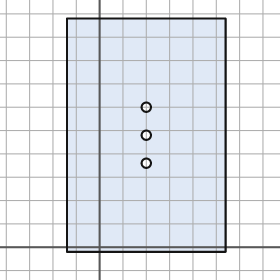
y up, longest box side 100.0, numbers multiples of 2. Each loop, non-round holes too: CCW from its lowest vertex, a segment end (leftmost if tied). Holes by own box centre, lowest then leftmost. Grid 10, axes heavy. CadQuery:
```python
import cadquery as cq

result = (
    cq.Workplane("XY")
    .moveTo(-14.0, -2.0)
    .lineTo(54.0, -2.0)
    .lineTo(54.0, 98.0)
    .lineTo(-14.0, 98.0)
    .close()
    .moveTo(20.0, 36.0)
    .circle(2.0)
    .moveTo(20.0, 48.0)
    .circle(2.0)
    .moveTo(20.0, 60.0)
    .circle(2.0)
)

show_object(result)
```